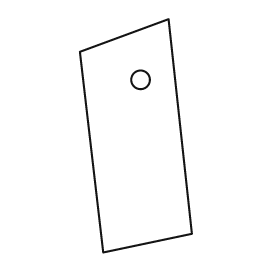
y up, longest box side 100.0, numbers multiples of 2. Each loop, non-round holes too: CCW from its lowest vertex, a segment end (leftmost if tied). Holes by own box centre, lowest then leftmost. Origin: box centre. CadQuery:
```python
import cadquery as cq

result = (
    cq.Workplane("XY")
    .moveTo(-14.0, -50.0)
    .lineTo(24.0, -42.0)
    .lineTo(14.0, 50.0)
    .lineTo(-24.0, 36.0)
    .close()
    .moveTo(2.0, 24.0)
    .circle(4.0)
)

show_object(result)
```